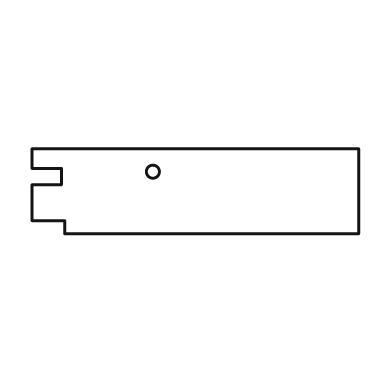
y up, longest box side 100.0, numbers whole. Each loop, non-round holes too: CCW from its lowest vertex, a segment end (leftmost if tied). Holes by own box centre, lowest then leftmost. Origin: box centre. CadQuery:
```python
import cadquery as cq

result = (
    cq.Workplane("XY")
    .moveTo(-40.0, -13.0)
    .lineTo(50.0, -13.0)
    .lineTo(50.0, 13.0)
    .lineTo(-50.0, 13.0)
    .lineTo(-50.0, 7.0)
    .lineTo(-41.0, 7.0)
    .lineTo(-41.0, 2.0)
    .lineTo(-50.0, 2.0)
    .lineTo(-50.0, -9.0)
    .lineTo(-40.0, -9.0)
    .close()
    .moveTo(-13.0, 6.0)
    .circle(2.0)
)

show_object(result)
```